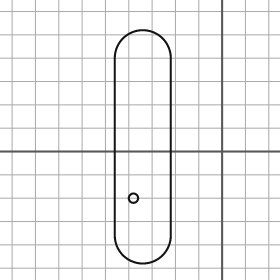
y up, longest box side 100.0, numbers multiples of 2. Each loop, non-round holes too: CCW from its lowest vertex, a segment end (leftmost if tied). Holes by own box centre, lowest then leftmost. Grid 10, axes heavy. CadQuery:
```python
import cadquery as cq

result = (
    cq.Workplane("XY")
    .moveTo(-46.0, -36.0)
    .threePointArc((-34.0, -48.0), (-22.0, -36.0))
    .lineTo(-22.0, 40.0)
    .threePointArc((-34.0, 52.0), (-46.0, 40.0))
    .close()
    .moveTo(-38.0, -20.0)
    .circle(2.0)
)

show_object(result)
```